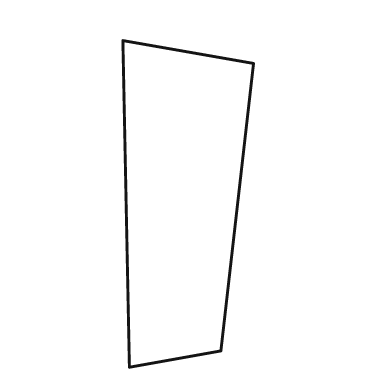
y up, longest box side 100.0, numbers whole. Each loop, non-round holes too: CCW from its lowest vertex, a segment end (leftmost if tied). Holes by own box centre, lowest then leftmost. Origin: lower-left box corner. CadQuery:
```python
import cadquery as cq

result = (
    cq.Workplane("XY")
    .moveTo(2.0, 0.0)
    .lineTo(30.0, 5.0)
    .lineTo(40.0, 93.0)
    .lineTo(0.0, 100.0)
    .close()
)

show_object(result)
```